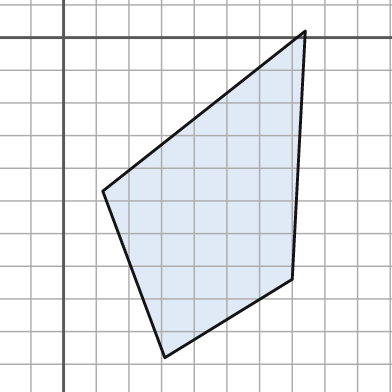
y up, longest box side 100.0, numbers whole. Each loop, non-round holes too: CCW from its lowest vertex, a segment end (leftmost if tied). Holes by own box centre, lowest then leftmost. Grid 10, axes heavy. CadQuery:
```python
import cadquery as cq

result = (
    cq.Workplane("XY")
    .moveTo(31.0, -98.0)
    .lineTo(70.0, -74.0)
    .lineTo(74.0, 2.0)
    .lineTo(12.0, -47.0)
    .close()
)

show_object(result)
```